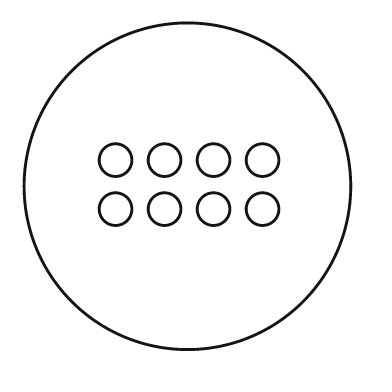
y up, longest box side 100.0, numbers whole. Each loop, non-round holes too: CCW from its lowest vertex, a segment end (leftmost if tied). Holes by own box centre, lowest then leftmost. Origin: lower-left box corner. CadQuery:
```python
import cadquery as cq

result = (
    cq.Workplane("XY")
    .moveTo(50.0, 50.0)
    .circle(50.0)
    .moveTo(28.0, 43.0)
    .circle(5.0)
    .moveTo(43.0, 43.0)
    .circle(5.0)
    .moveTo(58.0, 43.0)
    .circle(5.0)
    .moveTo(73.0, 43.0)
    .circle(5.0)
    .moveTo(28.0, 58.0)
    .circle(5.0)
    .moveTo(43.0, 58.0)
    .circle(5.0)
    .moveTo(58.0, 58.0)
    .circle(5.0)
    .moveTo(73.0, 58.0)
    .circle(5.0)
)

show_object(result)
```